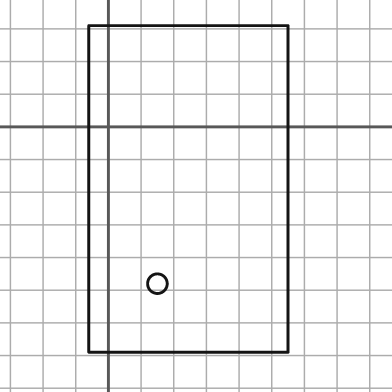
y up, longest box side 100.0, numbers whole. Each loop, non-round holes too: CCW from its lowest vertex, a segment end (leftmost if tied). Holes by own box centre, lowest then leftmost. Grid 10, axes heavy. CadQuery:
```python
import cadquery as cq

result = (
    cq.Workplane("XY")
    .moveTo(-6.0, -69.0)
    .lineTo(55.0, -69.0)
    .lineTo(55.0, 31.0)
    .lineTo(-6.0, 31.0)
    .close()
    .moveTo(15.0, -48.0)
    .circle(3.0)
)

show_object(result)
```